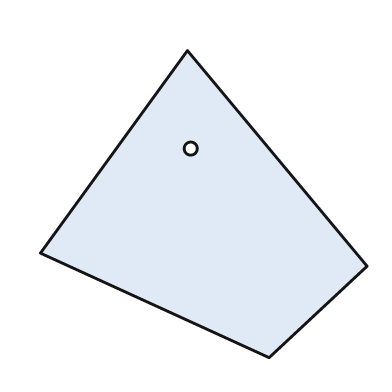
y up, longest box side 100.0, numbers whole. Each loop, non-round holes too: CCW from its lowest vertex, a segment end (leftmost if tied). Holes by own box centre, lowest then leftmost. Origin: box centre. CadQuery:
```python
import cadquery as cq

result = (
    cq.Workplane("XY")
    .moveTo(20.0, -47.0)
    .lineTo(50.0, -19.0)
    .lineTo(-5.0, 47.0)
    .lineTo(-50.0, -15.0)
    .close()
    .moveTo(-4.0, 17.0)
    .circle(2.0)
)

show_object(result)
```